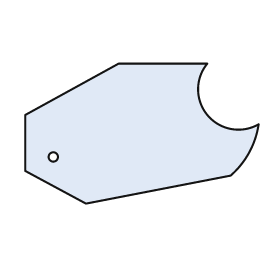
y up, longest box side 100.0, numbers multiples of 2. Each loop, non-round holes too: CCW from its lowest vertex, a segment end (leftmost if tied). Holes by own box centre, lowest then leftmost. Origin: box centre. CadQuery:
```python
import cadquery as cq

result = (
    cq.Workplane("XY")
    .moveTo(-24.0, -30.0)
    .lineTo(38.0, -18.0)
    .threePointArc((46.0, -8.0), (50.0, 4.0))
    .threePointArc((28.0, 8.0), (28.0, 30.0))
    .lineTo(-10.0, 30.0)
    .lineTo(-50.0, 8.0)
    .lineTo(-50.0, -16.0)
    .close()
    .moveTo(-38.0, -10.0)
    .circle(2.0)
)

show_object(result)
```